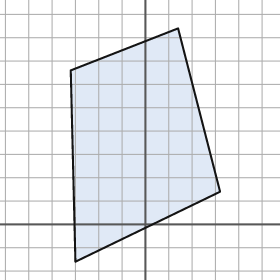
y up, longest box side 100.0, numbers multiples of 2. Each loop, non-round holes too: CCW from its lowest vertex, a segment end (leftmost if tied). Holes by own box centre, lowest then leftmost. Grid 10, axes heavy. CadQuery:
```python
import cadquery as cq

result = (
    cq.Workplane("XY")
    .moveTo(-30.0, -16.0)
    .lineTo(32.0, 14.0)
    .lineTo(14.0, 84.0)
    .lineTo(-32.0, 66.0)
    .close()
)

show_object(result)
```